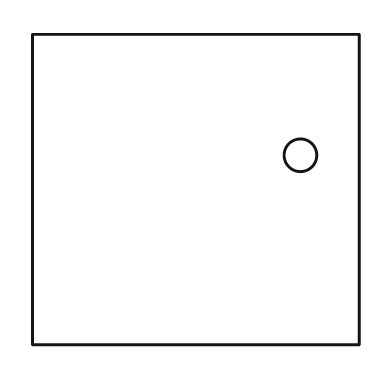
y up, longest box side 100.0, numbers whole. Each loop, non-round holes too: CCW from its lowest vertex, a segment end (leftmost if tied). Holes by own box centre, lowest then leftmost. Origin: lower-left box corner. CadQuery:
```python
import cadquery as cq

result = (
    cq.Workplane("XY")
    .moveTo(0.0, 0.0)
    .lineTo(100.0, 0.0)
    .lineTo(100.0, 95.0)
    .lineTo(0.0, 95.0)
    .close()
    .moveTo(82.0, 58.0)
    .circle(5.0)
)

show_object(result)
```